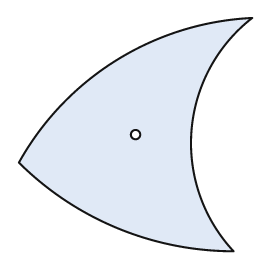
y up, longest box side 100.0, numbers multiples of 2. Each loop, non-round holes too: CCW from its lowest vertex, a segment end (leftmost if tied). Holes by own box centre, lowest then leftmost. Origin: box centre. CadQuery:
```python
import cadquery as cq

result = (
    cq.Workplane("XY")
    .moveTo(42.0, -50.0)
    .threePointArc((24.0, 2.0), (50.0, 50.0))
    .threePointArc((-8.0, 32.0), (-50.0, -12.0))
    .threePointArc((-8.0, -40.0), (42.0, -50.0))
    .close()
    .moveTo(0.0, 0.0)
    .circle(2.0)
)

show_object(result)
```